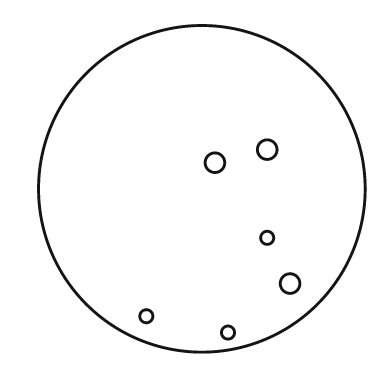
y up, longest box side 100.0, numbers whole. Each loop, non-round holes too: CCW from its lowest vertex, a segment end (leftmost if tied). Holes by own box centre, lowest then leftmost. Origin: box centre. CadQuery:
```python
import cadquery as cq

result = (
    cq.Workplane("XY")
    .moveTo(0.0, 0.0)
    .circle(50.0)
    .moveTo(8.0, -44.0)
    .circle(2.0)
    .moveTo(-17.0, -39.0)
    .circle(2.0)
    .moveTo(27.0, -29.0)
    .circle(3.0)
    .moveTo(20.0, -15.0)
    .circle(2.0)
    .moveTo(4.0, 8.0)
    .circle(3.0)
    .moveTo(20.0, 12.0)
    .circle(3.0)
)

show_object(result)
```